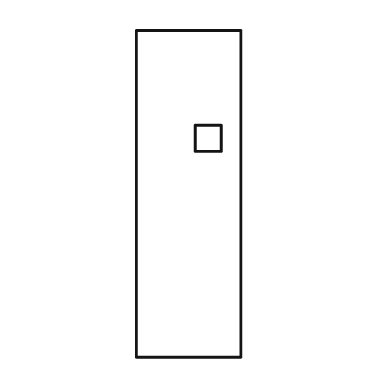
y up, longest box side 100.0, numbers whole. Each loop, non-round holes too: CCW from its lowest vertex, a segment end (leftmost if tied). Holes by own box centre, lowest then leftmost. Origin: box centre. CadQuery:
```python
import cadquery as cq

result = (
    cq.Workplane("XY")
    .moveTo(-16.0, -50.0)
    .lineTo(16.0, -50.0)
    .lineTo(16.0, 50.0)
    .lineTo(-16.0, 50.0)
    .close()
    .moveTo(2.0, 13.0)
    .lineTo(10.0, 13.0)
    .lineTo(10.0, 21.0)
    .lineTo(2.0, 21.0)
    .close()
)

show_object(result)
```